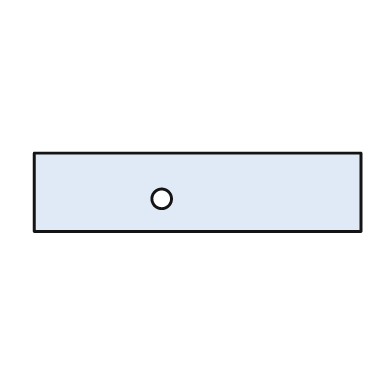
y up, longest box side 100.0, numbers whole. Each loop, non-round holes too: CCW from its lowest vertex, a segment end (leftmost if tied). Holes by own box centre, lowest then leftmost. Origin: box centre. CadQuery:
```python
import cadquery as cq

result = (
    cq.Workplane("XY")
    .moveTo(-50.0, -12.0)
    .lineTo(50.0, -12.0)
    .lineTo(50.0, 12.0)
    .lineTo(-50.0, 12.0)
    .close()
    .moveTo(-11.0, -2.0)
    .circle(3.0)
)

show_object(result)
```